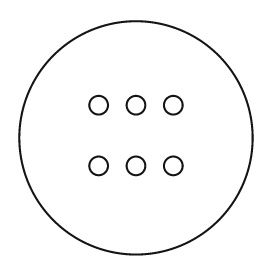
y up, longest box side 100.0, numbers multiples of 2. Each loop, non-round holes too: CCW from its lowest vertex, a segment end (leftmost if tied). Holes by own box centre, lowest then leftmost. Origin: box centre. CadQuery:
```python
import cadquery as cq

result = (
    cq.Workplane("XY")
    .moveTo(0.0, 0.0)
    .circle(50.0)
    .moveTo(-16.0, -12.0)
    .circle(4.0)
    .moveTo(0.0, -12.0)
    .circle(4.0)
    .moveTo(16.0, -12.0)
    .circle(4.0)
    .moveTo(-16.0, 14.0)
    .circle(4.0)
    .moveTo(0.0, 14.0)
    .circle(4.0)
    .moveTo(16.0, 14.0)
    .circle(4.0)
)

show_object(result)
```